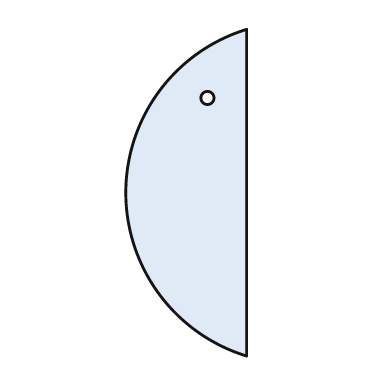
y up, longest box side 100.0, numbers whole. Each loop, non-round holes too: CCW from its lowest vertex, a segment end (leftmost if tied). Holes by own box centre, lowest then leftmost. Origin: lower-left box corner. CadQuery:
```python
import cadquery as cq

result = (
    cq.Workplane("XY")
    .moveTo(37.0, 0.0)
    .lineTo(37.0, 100.0)
    .threePointArc((0.0, 50.0), (37.0, 0.0))
    .close()
    .moveTo(25.0, 79.0)
    .circle(2.0)
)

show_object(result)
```